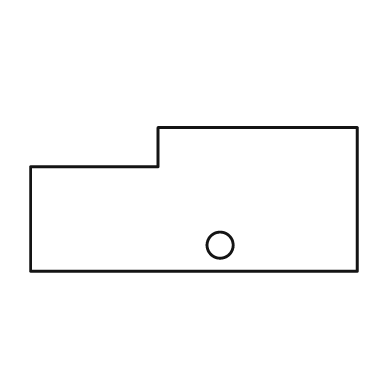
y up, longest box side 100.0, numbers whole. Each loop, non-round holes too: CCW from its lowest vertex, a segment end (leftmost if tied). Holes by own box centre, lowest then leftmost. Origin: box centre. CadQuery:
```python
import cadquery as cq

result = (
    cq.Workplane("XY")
    .moveTo(-50.0, -22.0)
    .lineTo(50.0, -22.0)
    .lineTo(50.0, 22.0)
    .lineTo(-11.0, 22.0)
    .lineTo(-11.0, 10.0)
    .lineTo(-50.0, 10.0)
    .close()
    .moveTo(8.0, -14.0)
    .circle(4.0)
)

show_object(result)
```